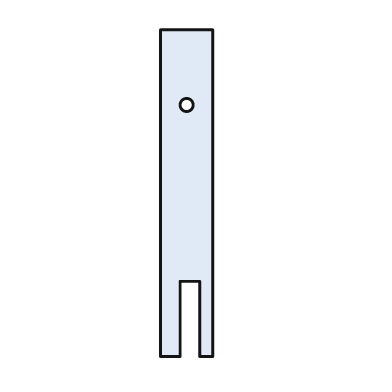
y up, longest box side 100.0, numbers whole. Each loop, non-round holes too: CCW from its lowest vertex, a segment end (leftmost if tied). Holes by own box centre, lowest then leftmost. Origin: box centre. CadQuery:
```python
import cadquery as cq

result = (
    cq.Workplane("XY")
    .moveTo(-8.0, -50.0)
    .lineTo(-2.0, -50.0)
    .lineTo(-2.0, -27.0)
    .lineTo(4.0, -27.0)
    .lineTo(4.0, -50.0)
    .lineTo(8.0, -50.0)
    .lineTo(8.0, 50.0)
    .lineTo(-8.0, 50.0)
    .close()
    .moveTo(0.0, 27.0)
    .circle(2.0)
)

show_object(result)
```